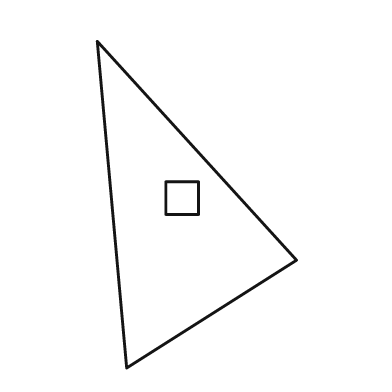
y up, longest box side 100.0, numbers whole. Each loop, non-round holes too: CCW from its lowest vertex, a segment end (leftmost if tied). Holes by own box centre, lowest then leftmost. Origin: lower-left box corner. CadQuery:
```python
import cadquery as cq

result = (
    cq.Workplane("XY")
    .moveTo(9.0, 0.0)
    .lineTo(61.0, 33.0)
    .lineTo(0.0, 100.0)
    .close()
    .moveTo(21.0, 47.0)
    .lineTo(31.0, 47.0)
    .lineTo(31.0, 57.0)
    .lineTo(21.0, 57.0)
    .close()
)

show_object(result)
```